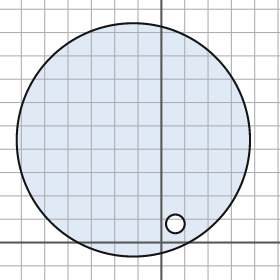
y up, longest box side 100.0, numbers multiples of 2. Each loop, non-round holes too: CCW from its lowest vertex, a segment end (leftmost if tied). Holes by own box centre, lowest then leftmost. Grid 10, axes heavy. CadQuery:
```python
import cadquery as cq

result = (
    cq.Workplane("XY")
    .moveTo(-12.0, 44.0)
    .circle(50.0)
    .moveTo(6.0, 8.0)
    .circle(4.0)
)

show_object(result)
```